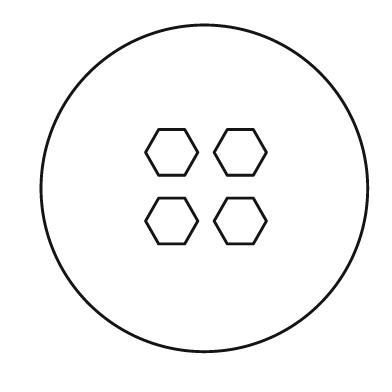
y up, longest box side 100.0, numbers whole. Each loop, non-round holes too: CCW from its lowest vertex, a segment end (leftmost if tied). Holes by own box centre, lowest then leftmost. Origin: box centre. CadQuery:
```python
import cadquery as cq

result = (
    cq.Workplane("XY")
    .moveTo(0.0, 0.0)
    .circle(50.0)
    .moveTo(-14.0, -17.0)
    .lineTo(-6.0, -17.0)
    .lineTo(-2.0, -10.0)
    .lineTo(-6.0, -3.0)
    .lineTo(-14.0, -3.0)
    .lineTo(-18.0, -10.0)
    .close()
    .moveTo(7.0, -17.0)
    .lineTo(15.0, -17.0)
    .lineTo(19.0, -10.0)
    .lineTo(15.0, -3.0)
    .lineTo(7.0, -3.0)
    .lineTo(3.0, -10.0)
    .close()
    .moveTo(-14.0, 4.0)
    .lineTo(-6.0, 4.0)
    .lineTo(-2.0, 11.0)
    .lineTo(-6.0, 18.0)
    .lineTo(-14.0, 18.0)
    .lineTo(-18.0, 11.0)
    .close()
    .moveTo(7.0, 4.0)
    .lineTo(15.0, 4.0)
    .lineTo(19.0, 11.0)
    .lineTo(15.0, 18.0)
    .lineTo(7.0, 18.0)
    .lineTo(3.0, 11.0)
    .close()
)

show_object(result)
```